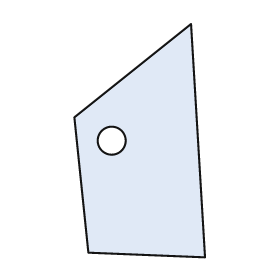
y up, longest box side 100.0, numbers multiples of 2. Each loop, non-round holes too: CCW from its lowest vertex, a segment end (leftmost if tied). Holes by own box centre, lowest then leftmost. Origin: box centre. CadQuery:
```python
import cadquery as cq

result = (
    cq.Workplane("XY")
    .moveTo(28.0, -50.0)
    .lineTo(22.0, 50.0)
    .lineTo(-28.0, 10.0)
    .lineTo(-22.0, -48.0)
    .close()
    .moveTo(-12.0, 0.0)
    .circle(6.0)
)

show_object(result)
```